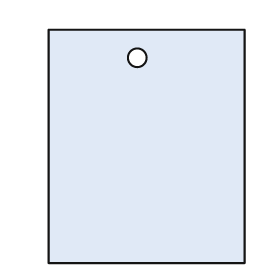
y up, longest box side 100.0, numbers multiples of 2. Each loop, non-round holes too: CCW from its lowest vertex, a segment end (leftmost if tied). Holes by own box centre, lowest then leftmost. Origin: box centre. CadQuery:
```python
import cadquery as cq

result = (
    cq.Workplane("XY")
    .moveTo(-42.0, -50.0)
    .lineTo(42.0, -50.0)
    .lineTo(42.0, 50.0)
    .lineTo(-42.0, 50.0)
    .close()
    .moveTo(-4.0, 38.0)
    .circle(4.0)
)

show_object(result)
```